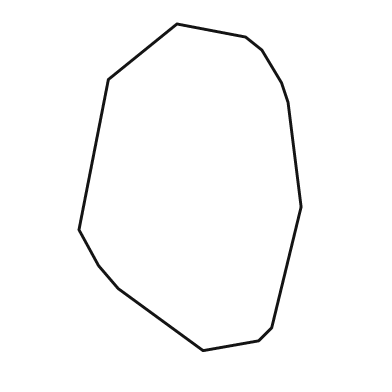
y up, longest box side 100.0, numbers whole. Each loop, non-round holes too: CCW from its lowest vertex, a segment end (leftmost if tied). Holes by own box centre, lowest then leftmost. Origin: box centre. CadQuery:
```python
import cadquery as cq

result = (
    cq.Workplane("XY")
    .moveTo(4.0, -50.0)
    .lineTo(21.0, -47.0)
    .lineTo(25.0, -43.0)
    .lineTo(34.0, -6.0)
    .lineTo(30.0, 26.0)
    .lineTo(28.0, 32.0)
    .lineTo(22.0, 42.0)
    .lineTo(17.0, 46.0)
    .lineTo(-4.0, 50.0)
    .lineTo(-25.0, 33.0)
    .lineTo(-34.0, -13.0)
    .lineTo(-28.0, -24.0)
    .lineTo(-22.0, -31.0)
    .close()
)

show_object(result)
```